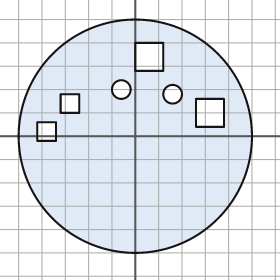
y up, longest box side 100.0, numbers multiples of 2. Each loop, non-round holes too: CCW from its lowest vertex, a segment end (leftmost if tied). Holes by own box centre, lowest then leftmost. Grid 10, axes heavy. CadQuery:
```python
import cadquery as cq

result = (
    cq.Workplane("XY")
    .moveTo(0.0, 0.0)
    .circle(50.0)
    .moveTo(-42.0, -2.0)
    .lineTo(-34.0, -2.0)
    .lineTo(-34.0, 6.0)
    .lineTo(-42.0, 6.0)
    .close()
    .moveTo(26.0, 4.0)
    .lineTo(38.0, 4.0)
    .lineTo(38.0, 16.0)
    .lineTo(26.0, 16.0)
    .close()
    .moveTo(-32.0, 10.0)
    .lineTo(-24.0, 10.0)
    .lineTo(-24.0, 18.0)
    .lineTo(-32.0, 18.0)
    .close()
    .moveTo(16.0, 18.0)
    .circle(4.0)
    .moveTo(-6.0, 20.0)
    .circle(4.0)
    .moveTo(0.0, 28.0)
    .lineTo(12.0, 28.0)
    .lineTo(12.0, 40.0)
    .lineTo(0.0, 40.0)
    .close()
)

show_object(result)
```